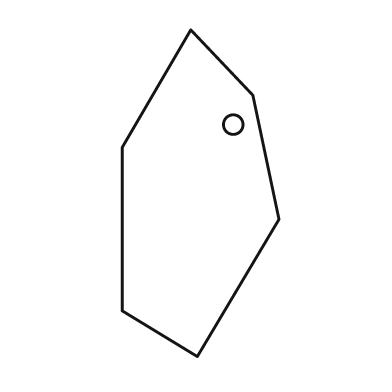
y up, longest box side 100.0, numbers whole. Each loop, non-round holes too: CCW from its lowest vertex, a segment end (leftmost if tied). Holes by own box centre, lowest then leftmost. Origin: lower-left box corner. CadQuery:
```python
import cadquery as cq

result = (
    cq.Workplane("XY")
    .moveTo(23.0, 0.0)
    .lineTo(48.0, 42.0)
    .lineTo(40.0, 80.0)
    .lineTo(21.0, 100.0)
    .lineTo(0.0, 64.0)
    .lineTo(0.0, 14.0)
    .close()
    .moveTo(34.0, 71.0)
    .circle(3.0)
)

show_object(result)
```